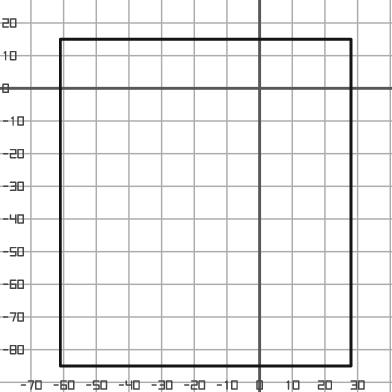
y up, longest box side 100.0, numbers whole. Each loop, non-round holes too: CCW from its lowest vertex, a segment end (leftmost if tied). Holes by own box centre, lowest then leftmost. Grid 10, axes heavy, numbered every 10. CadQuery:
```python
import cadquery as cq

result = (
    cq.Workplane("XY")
    .moveTo(-61.0, -85.0)
    .lineTo(28.0, -85.0)
    .lineTo(28.0, 15.0)
    .lineTo(-61.0, 15.0)
    .close()
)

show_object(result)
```